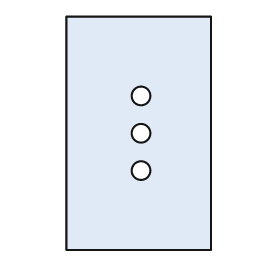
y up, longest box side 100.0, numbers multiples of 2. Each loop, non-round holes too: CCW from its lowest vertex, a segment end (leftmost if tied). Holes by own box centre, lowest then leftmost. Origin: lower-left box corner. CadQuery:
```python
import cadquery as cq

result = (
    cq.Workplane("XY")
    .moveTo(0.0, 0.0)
    .lineTo(62.0, 0.0)
    .lineTo(62.0, 100.0)
    .lineTo(0.0, 100.0)
    .close()
    .moveTo(32.0, 34.0)
    .circle(4.0)
    .moveTo(32.0, 50.0)
    .circle(4.0)
    .moveTo(32.0, 66.0)
    .circle(4.0)
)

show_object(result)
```